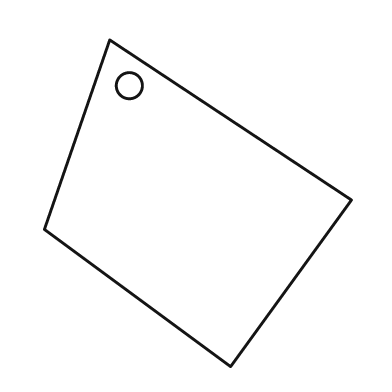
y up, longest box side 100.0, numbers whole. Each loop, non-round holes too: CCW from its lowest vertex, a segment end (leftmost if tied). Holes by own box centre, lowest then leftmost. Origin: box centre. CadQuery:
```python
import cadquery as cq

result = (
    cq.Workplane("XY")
    .moveTo(10.0, -50.0)
    .lineTo(47.0, 1.0)
    .lineTo(-27.0, 50.0)
    .lineTo(-47.0, -8.0)
    .close()
    .moveTo(-21.0, 36.0)
    .circle(4.0)
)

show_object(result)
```